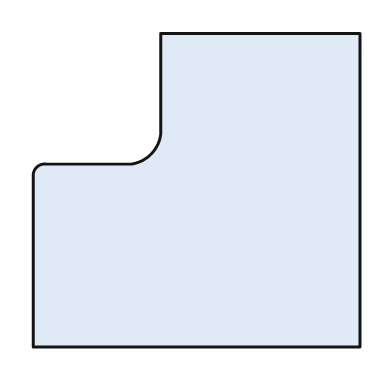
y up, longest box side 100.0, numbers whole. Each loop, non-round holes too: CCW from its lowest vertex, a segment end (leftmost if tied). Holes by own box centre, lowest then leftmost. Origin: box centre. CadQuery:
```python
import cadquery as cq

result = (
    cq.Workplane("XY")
    .moveTo(-50.0, -48.0)
    .lineTo(50.0, -48.0)
    .lineTo(50.0, 48.0)
    .lineTo(-11.0, 48.0)
    .lineTo(-11.0, 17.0)
    .threePointArc((-14.0, 11.0), (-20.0, 8.0))
    .lineTo(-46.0, 8.0)
    .threePointArc((-49.0, 7.0), (-50.0, 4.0))
    .close()
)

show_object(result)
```